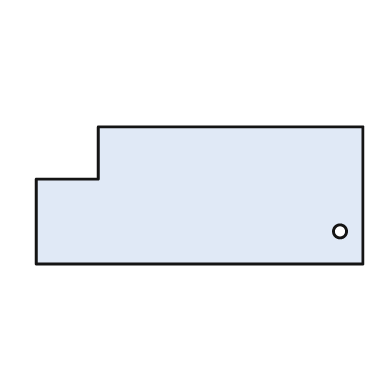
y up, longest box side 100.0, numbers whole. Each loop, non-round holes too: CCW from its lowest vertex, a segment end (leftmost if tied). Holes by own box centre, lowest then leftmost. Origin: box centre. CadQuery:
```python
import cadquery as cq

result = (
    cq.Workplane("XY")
    .moveTo(-50.0, -21.0)
    .lineTo(50.0, -21.0)
    .lineTo(50.0, 21.0)
    .lineTo(-31.0, 21.0)
    .lineTo(-31.0, 5.0)
    .lineTo(-50.0, 5.0)
    .close()
    .moveTo(43.0, -11.0)
    .circle(2.0)
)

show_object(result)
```